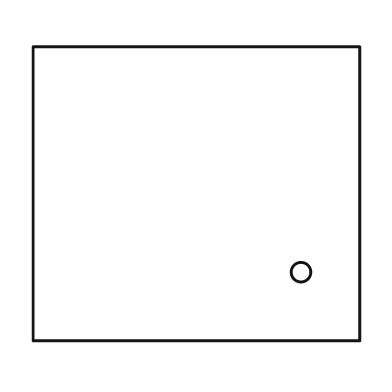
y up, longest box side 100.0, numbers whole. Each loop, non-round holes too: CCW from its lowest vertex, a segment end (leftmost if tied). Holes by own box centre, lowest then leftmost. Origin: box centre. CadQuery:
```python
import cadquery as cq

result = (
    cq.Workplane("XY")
    .moveTo(-50.0, -45.0)
    .lineTo(50.0, -45.0)
    .lineTo(50.0, 45.0)
    .lineTo(-50.0, 45.0)
    .close()
    .moveTo(32.0, -24.0)
    .circle(3.0)
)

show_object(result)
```